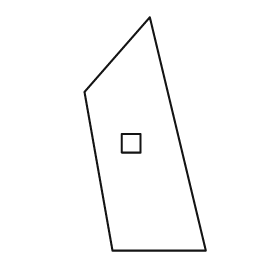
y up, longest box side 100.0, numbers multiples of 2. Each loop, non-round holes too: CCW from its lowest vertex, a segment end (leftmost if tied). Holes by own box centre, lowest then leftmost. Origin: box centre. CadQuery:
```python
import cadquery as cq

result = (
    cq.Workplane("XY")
    .moveTo(-14.0, -50.0)
    .lineTo(26.0, -50.0)
    .lineTo(2.0, 50.0)
    .lineTo(-26.0, 18.0)
    .close()
    .moveTo(-10.0, -8.0)
    .lineTo(-2.0, -8.0)
    .lineTo(-2.0, 0.0)
    .lineTo(-10.0, 0.0)
    .close()
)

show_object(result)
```